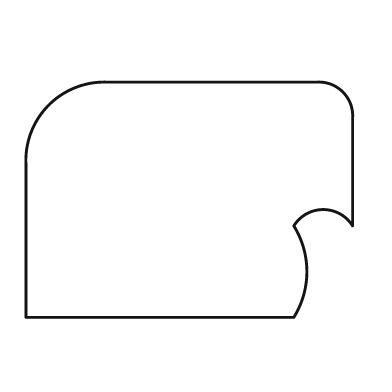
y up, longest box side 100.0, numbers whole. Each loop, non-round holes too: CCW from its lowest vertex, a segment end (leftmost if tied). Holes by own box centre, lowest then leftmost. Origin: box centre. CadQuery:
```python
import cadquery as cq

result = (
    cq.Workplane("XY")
    .moveTo(-50.0, -36.0)
    .lineTo(32.0, -36.0)
    .threePointArc((36.0, -22.0), (32.0, -8.0))
    .threePointArc((41.0, -3.0), (50.0, -8.0))
    .lineTo(50.0, 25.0)
    .threePointArc((47.0, 33.0), (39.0, 36.0))
    .lineTo(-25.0, 36.0)
    .threePointArc((-43.0, 29.0), (-50.0, 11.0))
    .close()
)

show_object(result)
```